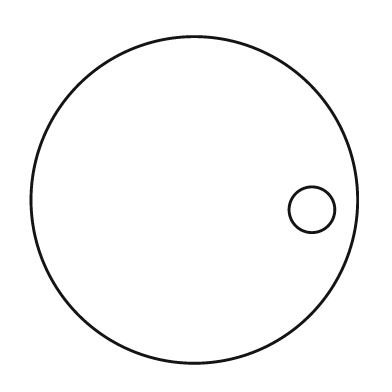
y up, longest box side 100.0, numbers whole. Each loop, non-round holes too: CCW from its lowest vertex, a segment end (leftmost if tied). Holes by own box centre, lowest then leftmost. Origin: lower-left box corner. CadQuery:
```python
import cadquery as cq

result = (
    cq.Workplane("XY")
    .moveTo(50.0, 50.0)
    .circle(50.0)
    .moveTo(86.0, 47.0)
    .circle(7.0)
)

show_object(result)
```